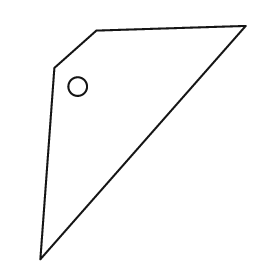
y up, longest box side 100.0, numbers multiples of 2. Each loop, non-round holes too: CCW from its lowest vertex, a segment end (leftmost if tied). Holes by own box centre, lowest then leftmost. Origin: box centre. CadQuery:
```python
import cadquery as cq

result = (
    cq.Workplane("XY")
    .moveTo(-44.0, -50.0)
    .lineTo(44.0, 50.0)
    .lineTo(-20.0, 48.0)
    .lineTo(-38.0, 32.0)
    .close()
    .moveTo(-28.0, 24.0)
    .circle(4.0)
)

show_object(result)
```